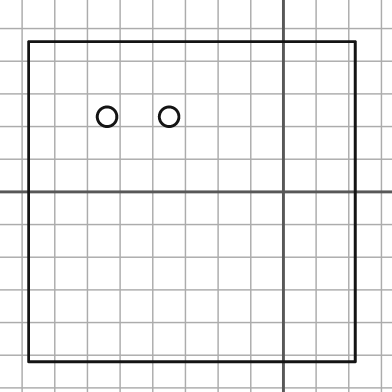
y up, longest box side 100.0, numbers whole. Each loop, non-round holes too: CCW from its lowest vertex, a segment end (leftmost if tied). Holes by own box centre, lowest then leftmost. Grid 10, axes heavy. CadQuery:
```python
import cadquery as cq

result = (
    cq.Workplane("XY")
    .moveTo(-78.0, -52.0)
    .lineTo(22.0, -52.0)
    .lineTo(22.0, 46.0)
    .lineTo(-78.0, 46.0)
    .close()
    .moveTo(-54.0, 23.0)
    .circle(3.0)
    .moveTo(-35.0, 23.0)
    .circle(3.0)
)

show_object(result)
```